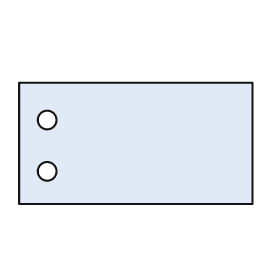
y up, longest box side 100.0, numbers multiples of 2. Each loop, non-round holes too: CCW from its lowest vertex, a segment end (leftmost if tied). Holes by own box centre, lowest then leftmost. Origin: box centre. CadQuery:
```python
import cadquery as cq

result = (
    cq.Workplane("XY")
    .moveTo(-50.0, -26.0)
    .lineTo(50.0, -26.0)
    .lineTo(50.0, 26.0)
    .lineTo(-50.0, 26.0)
    .close()
    .moveTo(-38.0, -12.0)
    .circle(4.0)
    .moveTo(-38.0, 10.0)
    .circle(4.0)
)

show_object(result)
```